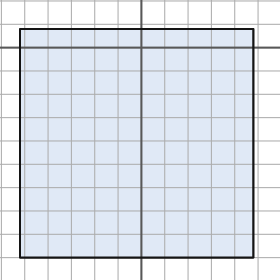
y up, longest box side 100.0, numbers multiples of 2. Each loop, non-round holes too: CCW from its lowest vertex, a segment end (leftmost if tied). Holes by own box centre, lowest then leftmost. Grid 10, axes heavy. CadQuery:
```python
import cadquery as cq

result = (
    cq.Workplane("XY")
    .moveTo(-52.0, -90.0)
    .lineTo(48.0, -90.0)
    .lineTo(48.0, 8.0)
    .lineTo(-52.0, 8.0)
    .close()
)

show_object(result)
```